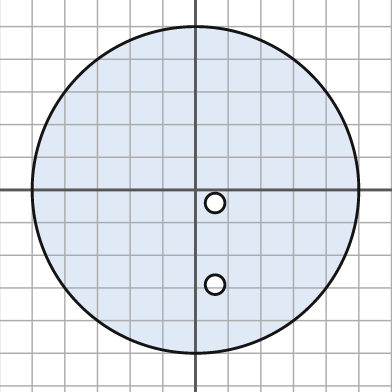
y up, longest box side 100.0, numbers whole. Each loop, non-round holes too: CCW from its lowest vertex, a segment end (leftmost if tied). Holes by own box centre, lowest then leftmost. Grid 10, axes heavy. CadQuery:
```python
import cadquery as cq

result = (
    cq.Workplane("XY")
    .moveTo(0.0, 0.0)
    .circle(50.0)
    .moveTo(6.0, -29.0)
    .circle(3.0)
    .moveTo(6.0, -4.0)
    .circle(3.0)
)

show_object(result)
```